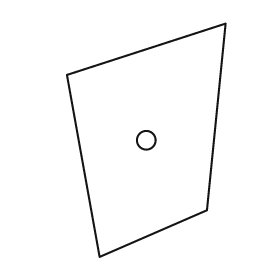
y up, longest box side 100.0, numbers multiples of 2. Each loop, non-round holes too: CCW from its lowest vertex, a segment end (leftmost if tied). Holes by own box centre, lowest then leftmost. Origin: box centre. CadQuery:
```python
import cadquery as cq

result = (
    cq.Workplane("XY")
    .moveTo(-20.0, -50.0)
    .lineTo(26.0, -30.0)
    .lineTo(34.0, 50.0)
    .lineTo(-34.0, 28.0)
    .close()
    .moveTo(0.0, 0.0)
    .circle(4.0)
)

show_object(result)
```